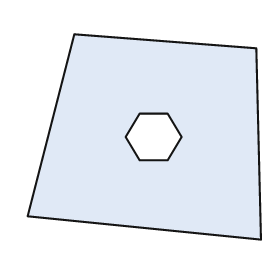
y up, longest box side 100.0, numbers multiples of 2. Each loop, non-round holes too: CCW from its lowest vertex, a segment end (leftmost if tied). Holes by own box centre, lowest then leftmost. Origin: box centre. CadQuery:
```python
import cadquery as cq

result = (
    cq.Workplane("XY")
    .moveTo(50.0, -44.0)
    .lineTo(48.0, 38.0)
    .lineTo(-30.0, 44.0)
    .lineTo(-50.0, -34.0)
    .close()
    .moveTo(-2.0, -10.0)
    .lineTo(10.0, -10.0)
    .lineTo(16.0, 0.0)
    .lineTo(10.0, 10.0)
    .lineTo(-2.0, 10.0)
    .lineTo(-8.0, 0.0)
    .close()
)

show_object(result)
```